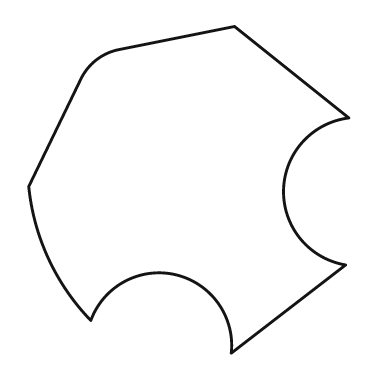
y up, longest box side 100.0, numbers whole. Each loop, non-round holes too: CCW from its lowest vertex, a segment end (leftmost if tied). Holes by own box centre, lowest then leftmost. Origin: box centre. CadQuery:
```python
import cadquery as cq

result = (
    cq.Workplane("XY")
    .moveTo(13.0, -50.0)
    .lineTo(48.0, -23.0)
    .threePointArc((29.0, 0.0), (49.0, 22.0))
    .lineTo(14.0, 50.0)
    .lineTo(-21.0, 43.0)
    .threePointArc((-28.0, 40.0), (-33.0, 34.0))
    .lineTo(-49.0, 1.0)
    .threePointArc((-43.0, -21.0), (-30.0, -40.0))
    .threePointArc((-4.0, -26.0), (13.0, -50.0))
    .close()
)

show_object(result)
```